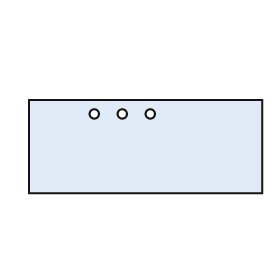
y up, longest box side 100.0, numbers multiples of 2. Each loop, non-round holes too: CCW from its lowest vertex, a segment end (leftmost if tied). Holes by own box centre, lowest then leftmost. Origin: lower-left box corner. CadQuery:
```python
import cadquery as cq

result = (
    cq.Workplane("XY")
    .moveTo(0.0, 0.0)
    .lineTo(100.0, 0.0)
    .lineTo(100.0, 40.0)
    .lineTo(0.0, 40.0)
    .close()
    .moveTo(28.0, 34.0)
    .circle(2.0)
    .moveTo(40.0, 34.0)
    .circle(2.0)
    .moveTo(52.0, 34.0)
    .circle(2.0)
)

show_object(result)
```